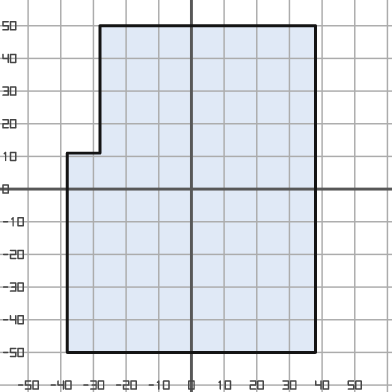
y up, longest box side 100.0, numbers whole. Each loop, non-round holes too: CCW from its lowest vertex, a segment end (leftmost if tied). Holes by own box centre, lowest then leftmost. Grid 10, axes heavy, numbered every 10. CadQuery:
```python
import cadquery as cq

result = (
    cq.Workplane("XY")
    .moveTo(-38.0, -50.0)
    .lineTo(38.0, -50.0)
    .lineTo(38.0, 50.0)
    .lineTo(-28.0, 50.0)
    .lineTo(-28.0, 11.0)
    .lineTo(-38.0, 11.0)
    .close()
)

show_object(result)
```